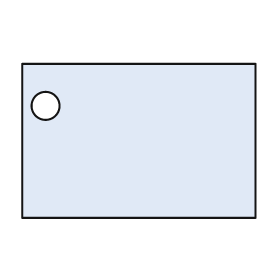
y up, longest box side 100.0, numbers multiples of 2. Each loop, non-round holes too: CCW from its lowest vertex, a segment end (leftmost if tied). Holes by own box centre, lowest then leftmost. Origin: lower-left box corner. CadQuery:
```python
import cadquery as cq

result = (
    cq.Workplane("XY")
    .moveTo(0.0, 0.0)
    .lineTo(100.0, 0.0)
    .lineTo(100.0, 66.0)
    .lineTo(0.0, 66.0)
    .close()
    .moveTo(10.0, 48.0)
    .circle(6.0)
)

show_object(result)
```